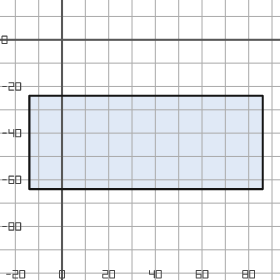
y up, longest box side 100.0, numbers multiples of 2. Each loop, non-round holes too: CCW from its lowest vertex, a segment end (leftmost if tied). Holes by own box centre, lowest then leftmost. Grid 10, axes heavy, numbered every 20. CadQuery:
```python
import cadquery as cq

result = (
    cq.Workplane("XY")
    .moveTo(-14.0, -64.0)
    .lineTo(86.0, -64.0)
    .lineTo(86.0, -24.0)
    .lineTo(-14.0, -24.0)
    .close()
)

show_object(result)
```